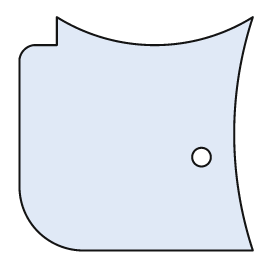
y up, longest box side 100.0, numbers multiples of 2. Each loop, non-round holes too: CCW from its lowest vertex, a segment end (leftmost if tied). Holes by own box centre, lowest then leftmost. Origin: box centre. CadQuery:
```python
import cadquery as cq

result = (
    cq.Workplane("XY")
    .moveTo(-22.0, -50.0)
    .lineTo(50.0, -50.0)
    .threePointArc((42.0, 0.0), (50.0, 50.0))
    .threePointArc((8.0, 38.0), (-34.0, 50.0))
    .lineTo(-34.0, 38.0)
    .lineTo(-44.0, 38.0)
    .threePointArc((-48.0, 36.0), (-50.0, 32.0))
    .lineTo(-50.0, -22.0)
    .threePointArc((-42.0, -42.0), (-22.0, -50.0))
    .close()
    .moveTo(28.0, -10.0)
    .circle(4.0)
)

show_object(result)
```